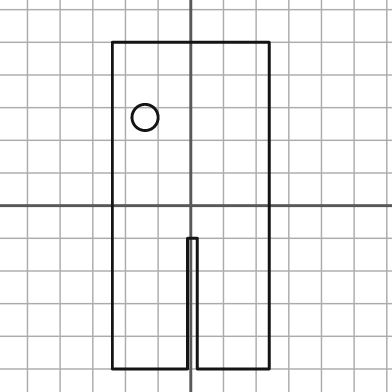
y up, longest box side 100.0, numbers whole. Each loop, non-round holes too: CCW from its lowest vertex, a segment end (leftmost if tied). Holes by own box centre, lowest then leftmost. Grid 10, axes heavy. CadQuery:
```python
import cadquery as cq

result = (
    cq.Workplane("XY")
    .moveTo(-24.0, -50.0)
    .lineTo(-1.0, -50.0)
    .lineTo(-1.0, -10.0)
    .lineTo(2.0, -10.0)
    .lineTo(2.0, -50.0)
    .lineTo(24.0, -50.0)
    .lineTo(24.0, 50.0)
    .lineTo(-24.0, 50.0)
    .close()
    .moveTo(-14.0, 27.0)
    .circle(4.0)
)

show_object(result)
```